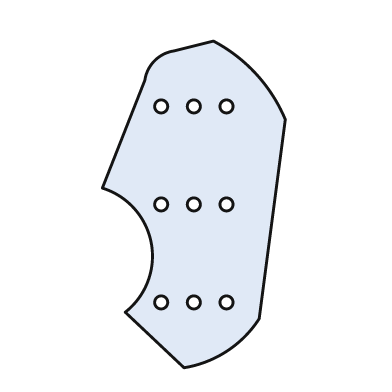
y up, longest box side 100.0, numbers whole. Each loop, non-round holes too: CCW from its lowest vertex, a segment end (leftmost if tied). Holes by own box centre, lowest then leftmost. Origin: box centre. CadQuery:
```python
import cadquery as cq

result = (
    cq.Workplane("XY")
    .moveTo(-3.0, -50.0)
    .threePointArc((10.0, -45.0), (20.0, -35.0))
    .lineTo(28.0, 26.0)
    .threePointArc((19.0, 40.0), (6.0, 50.0))
    .lineTo(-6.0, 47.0)
    .threePointArc((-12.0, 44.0), (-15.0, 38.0))
    .lineTo(-28.0, 5.0)
    .threePointArc((-13.0, -12.0), (-21.0, -33.0))
    .close()
    .moveTo(-10.0, -30.0)
    .circle(2.0)
    .moveTo(0.0, -30.0)
    .circle(2.0)
    .moveTo(10.0, -30.0)
    .circle(2.0)
    .moveTo(-10.0, 0.0)
    .circle(2.0)
    .moveTo(0.0, 0.0)
    .circle(2.0)
    .moveTo(10.0, 0.0)
    .circle(2.0)
    .moveTo(-10.0, 30.0)
    .circle(2.0)
    .moveTo(0.0, 30.0)
    .circle(2.0)
    .moveTo(10.0, 30.0)
    .circle(2.0)
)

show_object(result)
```